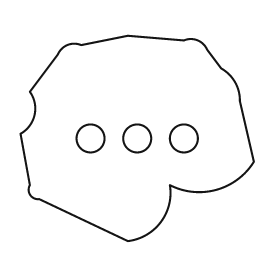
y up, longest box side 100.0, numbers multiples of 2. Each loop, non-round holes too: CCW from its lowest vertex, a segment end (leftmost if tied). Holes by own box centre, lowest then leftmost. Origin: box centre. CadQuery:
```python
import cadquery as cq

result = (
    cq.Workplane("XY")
    .moveTo(-4.0, -44.0)
    .threePointArc((10.0, -36.0), (14.0, -20.0))
    .threePointArc((34.0, -22.0), (50.0, -10.0))
    .lineTo(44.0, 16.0)
    .threePointArc((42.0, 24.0), (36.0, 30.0))
    .lineTo(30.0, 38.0)
    .threePointArc((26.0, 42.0), (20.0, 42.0))
    .lineTo(-4.0, 44.0)
    .lineTo(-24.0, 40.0)
    .threePointArc((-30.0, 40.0), (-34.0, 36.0))
    .lineTo(-46.0, 20.0)
    .threePointArc((-44.0, 10.0), (-50.0, 2.0))
    .lineTo(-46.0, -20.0)
    .threePointArc((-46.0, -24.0), (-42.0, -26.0))
    .close()
    .moveTo(-20.0, 0.0)
    .circle(6.0)
    .moveTo(0.0, 0.0)
    .circle(6.0)
    .moveTo(20.0, 0.0)
    .circle(6.0)
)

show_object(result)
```